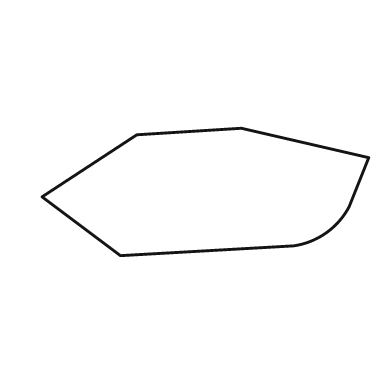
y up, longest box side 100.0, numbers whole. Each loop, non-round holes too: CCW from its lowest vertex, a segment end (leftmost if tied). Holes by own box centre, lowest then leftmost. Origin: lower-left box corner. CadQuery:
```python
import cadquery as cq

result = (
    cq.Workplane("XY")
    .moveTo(24.0, 0.0)
    .lineTo(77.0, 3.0)
    .threePointArc((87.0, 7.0), (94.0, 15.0))
    .lineTo(100.0, 30.0)
    .lineTo(61.0, 39.0)
    .lineTo(29.0, 37.0)
    .lineTo(0.0, 18.0)
    .close()
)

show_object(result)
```